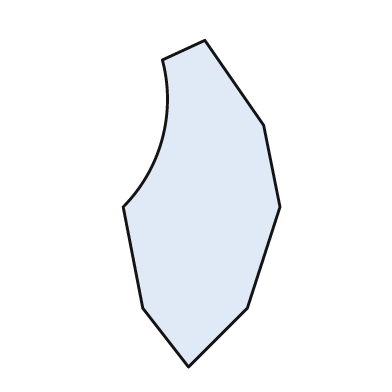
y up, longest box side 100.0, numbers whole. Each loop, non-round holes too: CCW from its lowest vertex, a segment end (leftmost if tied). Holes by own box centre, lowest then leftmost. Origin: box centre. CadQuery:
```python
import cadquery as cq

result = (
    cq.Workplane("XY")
    .moveTo(-4.0, -50.0)
    .lineTo(14.0, -32.0)
    .lineTo(24.0, -1.0)
    .lineTo(19.0, 24.0)
    .lineTo(1.0, 50.0)
    .lineTo(-12.0, 44.0)
    .threePointArc((-12.0, 20.0), (-24.0, -1.0))
    .lineTo(-18.0, -32.0)
    .close()
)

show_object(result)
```